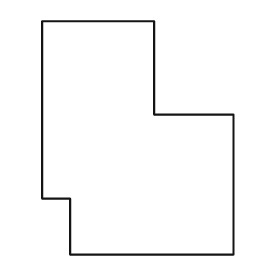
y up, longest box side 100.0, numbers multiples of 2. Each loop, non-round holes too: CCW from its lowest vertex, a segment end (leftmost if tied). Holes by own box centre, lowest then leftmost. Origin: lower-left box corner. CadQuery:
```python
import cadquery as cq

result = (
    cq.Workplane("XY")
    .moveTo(12.0, 0.0)
    .lineTo(82.0, 0.0)
    .lineTo(82.0, 60.0)
    .lineTo(48.0, 60.0)
    .lineTo(48.0, 100.0)
    .lineTo(0.0, 100.0)
    .lineTo(0.0, 24.0)
    .lineTo(12.0, 24.0)
    .close()
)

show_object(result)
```